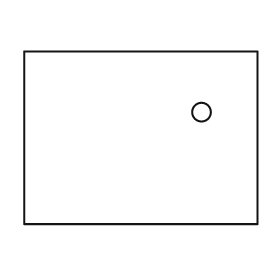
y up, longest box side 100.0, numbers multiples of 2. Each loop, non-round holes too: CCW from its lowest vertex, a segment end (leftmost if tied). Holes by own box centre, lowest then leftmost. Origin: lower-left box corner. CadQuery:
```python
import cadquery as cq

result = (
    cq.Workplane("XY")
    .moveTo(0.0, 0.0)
    .lineTo(100.0, 0.0)
    .lineTo(100.0, 74.0)
    .lineTo(0.0, 74.0)
    .close()
    .moveTo(76.0, 48.0)
    .circle(4.0)
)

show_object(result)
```